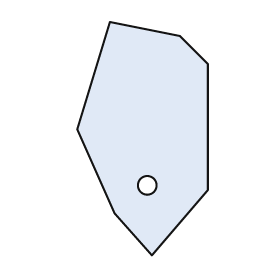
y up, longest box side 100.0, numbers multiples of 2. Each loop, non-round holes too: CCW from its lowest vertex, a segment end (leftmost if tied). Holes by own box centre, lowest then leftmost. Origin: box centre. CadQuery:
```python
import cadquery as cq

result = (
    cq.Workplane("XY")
    .moveTo(4.0, -50.0)
    .lineTo(28.0, -22.0)
    .lineTo(28.0, 32.0)
    .lineTo(16.0, 44.0)
    .lineTo(-14.0, 50.0)
    .lineTo(-28.0, 4.0)
    .lineTo(-12.0, -32.0)
    .close()
    .moveTo(2.0, -20.0)
    .circle(4.0)
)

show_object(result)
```